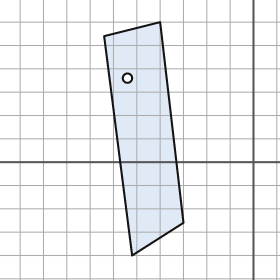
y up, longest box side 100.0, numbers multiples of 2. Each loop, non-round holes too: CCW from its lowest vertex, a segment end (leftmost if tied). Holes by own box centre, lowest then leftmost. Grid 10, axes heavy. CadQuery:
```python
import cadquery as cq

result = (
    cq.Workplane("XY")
    .moveTo(-52.0, -40.0)
    .lineTo(-30.0, -26.0)
    .lineTo(-40.0, 60.0)
    .lineTo(-64.0, 54.0)
    .close()
    .moveTo(-54.0, 36.0)
    .circle(2.0)
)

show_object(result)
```